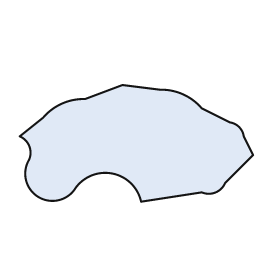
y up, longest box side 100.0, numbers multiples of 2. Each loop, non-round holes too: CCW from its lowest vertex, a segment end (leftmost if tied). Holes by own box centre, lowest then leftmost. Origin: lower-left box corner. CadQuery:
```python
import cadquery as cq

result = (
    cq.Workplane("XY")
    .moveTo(52.0, 0.0)
    .lineTo(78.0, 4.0)
    .threePointArc((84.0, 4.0), (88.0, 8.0))
    .lineTo(100.0, 20.0)
    .lineTo(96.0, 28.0)
    .threePointArc((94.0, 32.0), (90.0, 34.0))
    .lineTo(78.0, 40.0)
    .threePointArc((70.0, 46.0), (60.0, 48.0))
    .lineTo(44.0, 50.0)
    .lineTo(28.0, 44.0)
    .threePointArc((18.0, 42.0), (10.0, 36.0))
    .lineTo(0.0, 28.0)
    .threePointArc((4.0, 24.0), (4.0, 18.0))
    .threePointArc((8.0, 2.0), (24.0, 6.0))
    .threePointArc((40.0, 12.0), (52.0, 0.0))
    .close()
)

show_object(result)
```